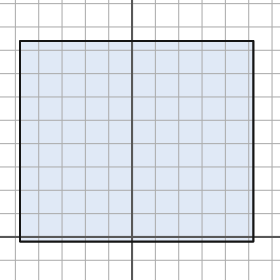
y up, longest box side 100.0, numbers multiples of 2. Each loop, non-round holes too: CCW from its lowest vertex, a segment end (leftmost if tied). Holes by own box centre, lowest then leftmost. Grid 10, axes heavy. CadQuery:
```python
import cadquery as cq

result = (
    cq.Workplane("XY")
    .moveTo(-48.0, -2.0)
    .lineTo(52.0, -2.0)
    .lineTo(52.0, 84.0)
    .lineTo(-48.0, 84.0)
    .close()
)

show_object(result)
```